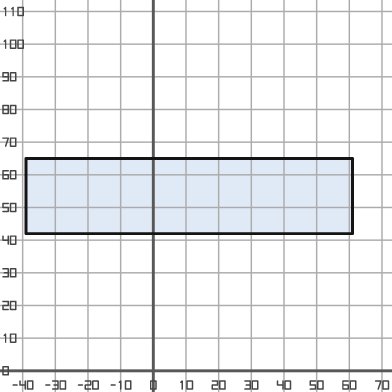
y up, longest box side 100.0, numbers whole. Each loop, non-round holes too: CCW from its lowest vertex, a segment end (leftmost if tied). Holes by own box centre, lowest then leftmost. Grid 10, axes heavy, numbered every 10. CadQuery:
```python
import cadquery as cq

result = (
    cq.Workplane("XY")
    .moveTo(-39.0, 42.0)
    .lineTo(61.0, 42.0)
    .lineTo(61.0, 65.0)
    .lineTo(-39.0, 65.0)
    .close()
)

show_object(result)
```